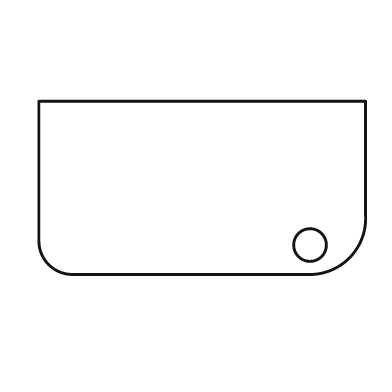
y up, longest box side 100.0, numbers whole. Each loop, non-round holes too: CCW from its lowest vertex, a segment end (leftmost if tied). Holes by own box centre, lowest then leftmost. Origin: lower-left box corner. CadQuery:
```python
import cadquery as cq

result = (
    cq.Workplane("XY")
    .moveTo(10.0, 0.0)
    .lineTo(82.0, 0.0)
    .threePointArc((95.0, 5.0), (100.0, 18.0))
    .lineTo(100.0, 53.0)
    .lineTo(0.0, 53.0)
    .lineTo(0.0, 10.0)
    .threePointArc((3.0, 3.0), (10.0, 0.0))
    .close()
    .moveTo(83.0, 9.0)
    .circle(5.0)
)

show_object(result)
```